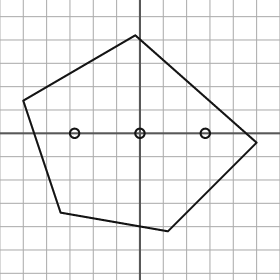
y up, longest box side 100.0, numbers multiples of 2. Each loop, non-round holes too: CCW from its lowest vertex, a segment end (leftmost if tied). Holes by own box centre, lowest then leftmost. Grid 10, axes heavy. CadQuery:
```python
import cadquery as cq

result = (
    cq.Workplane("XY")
    .moveTo(12.0, -42.0)
    .lineTo(50.0, -4.0)
    .lineTo(-2.0, 42.0)
    .lineTo(-50.0, 14.0)
    .lineTo(-34.0, -34.0)
    .close()
    .moveTo(-28.0, 0.0)
    .circle(2.0)
    .moveTo(0.0, 0.0)
    .circle(2.0)
    .moveTo(28.0, 0.0)
    .circle(2.0)
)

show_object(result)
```